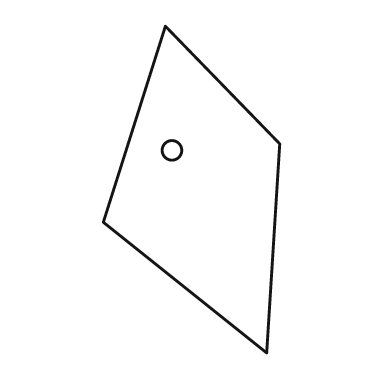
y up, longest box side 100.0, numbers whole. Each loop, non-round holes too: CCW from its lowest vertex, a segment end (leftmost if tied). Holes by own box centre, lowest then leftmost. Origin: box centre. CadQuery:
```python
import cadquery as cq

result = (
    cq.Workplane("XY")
    .moveTo(23.0, -50.0)
    .lineTo(27.0, 14.0)
    .lineTo(-8.0, 50.0)
    .lineTo(-27.0, -10.0)
    .close()
    .moveTo(-6.0, 12.0)
    .circle(3.0)
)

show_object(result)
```